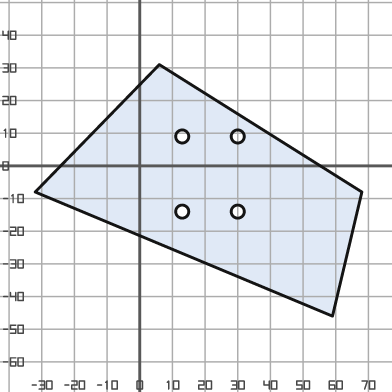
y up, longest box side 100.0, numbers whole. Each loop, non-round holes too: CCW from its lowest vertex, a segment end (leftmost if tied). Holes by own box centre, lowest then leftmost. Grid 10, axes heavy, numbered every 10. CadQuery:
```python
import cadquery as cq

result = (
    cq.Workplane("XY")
    .moveTo(59.0, -46.0)
    .lineTo(68.0, -8.0)
    .lineTo(6.0, 31.0)
    .lineTo(-32.0, -8.0)
    .close()
    .moveTo(13.0, -14.0)
    .circle(2.0)
    .moveTo(30.0, -14.0)
    .circle(2.0)
    .moveTo(13.0, 9.0)
    .circle(2.0)
    .moveTo(30.0, 9.0)
    .circle(2.0)
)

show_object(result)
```